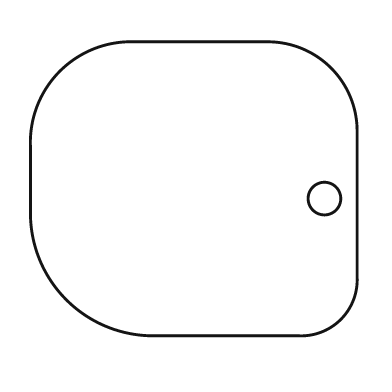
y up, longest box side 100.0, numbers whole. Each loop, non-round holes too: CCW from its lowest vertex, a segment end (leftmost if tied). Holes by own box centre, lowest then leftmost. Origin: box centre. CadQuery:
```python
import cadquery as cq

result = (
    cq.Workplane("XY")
    .moveTo(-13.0, -45.0)
    .lineTo(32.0, -45.0)
    .threePointArc((45.0, -40.0), (50.0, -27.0))
    .lineTo(50.0, 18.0)
    .threePointArc((42.0, 37.0), (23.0, 45.0))
    .lineTo(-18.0, 45.0)
    .threePointArc((-41.0, 36.0), (-50.0, 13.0))
    .lineTo(-50.0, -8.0)
    .threePointArc((-39.0, -34.0), (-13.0, -45.0))
    .close()
    .moveTo(40.0, -3.0)
    .circle(5.0)
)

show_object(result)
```